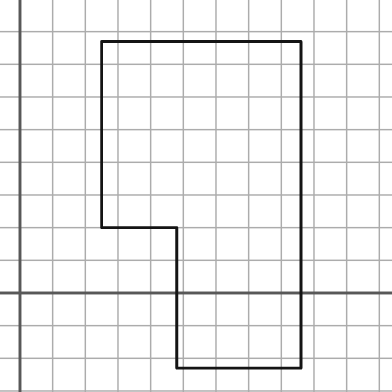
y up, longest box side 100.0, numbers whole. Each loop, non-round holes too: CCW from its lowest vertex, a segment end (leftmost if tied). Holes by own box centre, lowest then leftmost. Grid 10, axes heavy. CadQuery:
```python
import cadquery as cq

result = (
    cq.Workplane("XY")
    .moveTo(48.0, -23.0)
    .lineTo(86.0, -23.0)
    .lineTo(86.0, 77.0)
    .lineTo(25.0, 77.0)
    .lineTo(25.0, 20.0)
    .lineTo(48.0, 20.0)
    .close()
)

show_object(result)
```